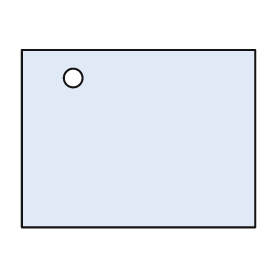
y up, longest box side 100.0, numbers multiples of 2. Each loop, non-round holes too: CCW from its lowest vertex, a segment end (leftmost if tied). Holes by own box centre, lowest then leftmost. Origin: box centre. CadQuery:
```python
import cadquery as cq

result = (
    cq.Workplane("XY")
    .moveTo(-50.0, -38.0)
    .lineTo(50.0, -38.0)
    .lineTo(50.0, 38.0)
    .lineTo(-50.0, 38.0)
    .close()
    .moveTo(-28.0, 26.0)
    .circle(4.0)
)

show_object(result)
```